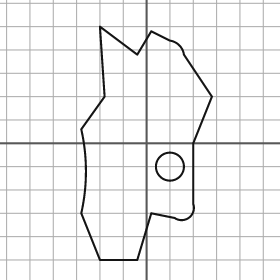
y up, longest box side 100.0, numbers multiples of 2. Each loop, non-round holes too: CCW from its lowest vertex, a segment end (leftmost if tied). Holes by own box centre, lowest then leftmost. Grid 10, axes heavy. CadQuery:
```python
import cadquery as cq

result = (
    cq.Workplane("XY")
    .moveTo(-20.0, -50.0)
    .lineTo(-4.0, -50.0)
    .lineTo(2.0, -30.0)
    .lineTo(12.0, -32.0)
    .threePointArc((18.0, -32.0), (20.0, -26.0))
    .lineTo(20.0, 0.0)
    .lineTo(28.0, 20.0)
    .lineTo(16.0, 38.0)
    .threePointArc((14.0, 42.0), (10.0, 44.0))
    .lineTo(2.0, 48.0)
    .lineTo(-4.0, 38.0)
    .lineTo(-20.0, 50.0)
    .lineTo(-18.0, 20.0)
    .lineTo(-28.0, 6.0)
    .threePointArc((-26.0, -12.0), (-28.0, -30.0))
    .close()
    .moveTo(10.0, -10.0)
    .circle(6.0)
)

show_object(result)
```